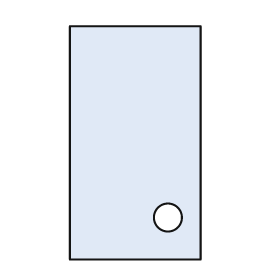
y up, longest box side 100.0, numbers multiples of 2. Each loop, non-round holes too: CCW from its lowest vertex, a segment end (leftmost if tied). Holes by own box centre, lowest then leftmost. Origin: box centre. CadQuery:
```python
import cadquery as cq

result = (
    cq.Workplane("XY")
    .moveTo(-28.0, -50.0)
    .lineTo(28.0, -50.0)
    .lineTo(28.0, 50.0)
    .lineTo(-28.0, 50.0)
    .close()
    .moveTo(14.0, -32.0)
    .circle(6.0)
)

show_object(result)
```